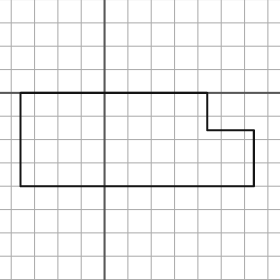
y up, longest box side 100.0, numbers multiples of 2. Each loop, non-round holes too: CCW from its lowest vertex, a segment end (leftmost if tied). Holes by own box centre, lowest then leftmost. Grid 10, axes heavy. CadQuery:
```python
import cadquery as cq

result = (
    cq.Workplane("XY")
    .moveTo(-36.0, -40.0)
    .lineTo(64.0, -40.0)
    .lineTo(64.0, -16.0)
    .lineTo(44.0, -16.0)
    .lineTo(44.0, 0.0)
    .lineTo(-36.0, 0.0)
    .close()
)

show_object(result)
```